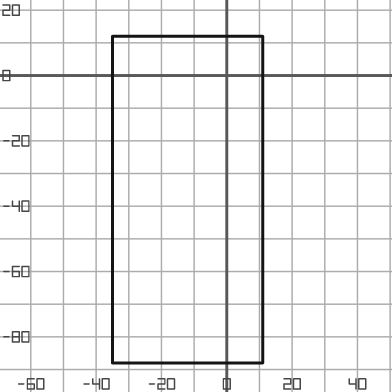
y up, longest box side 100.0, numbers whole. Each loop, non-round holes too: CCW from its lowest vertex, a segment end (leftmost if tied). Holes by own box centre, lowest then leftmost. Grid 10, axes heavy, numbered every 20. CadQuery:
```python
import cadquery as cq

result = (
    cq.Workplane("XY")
    .moveTo(-35.0, -88.0)
    .lineTo(11.0, -88.0)
    .lineTo(11.0, 12.0)
    .lineTo(-35.0, 12.0)
    .close()
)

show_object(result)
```